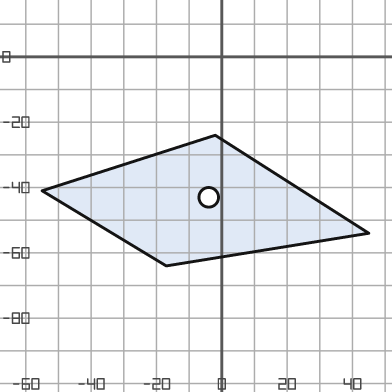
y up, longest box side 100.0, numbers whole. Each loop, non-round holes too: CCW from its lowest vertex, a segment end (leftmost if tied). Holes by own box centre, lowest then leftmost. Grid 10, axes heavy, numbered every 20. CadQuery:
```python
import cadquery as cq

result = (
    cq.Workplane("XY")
    .moveTo(-17.0, -64.0)
    .lineTo(45.0, -54.0)
    .lineTo(-2.0, -24.0)
    .lineTo(-55.0, -41.0)
    .close()
    .moveTo(-4.0, -43.0)
    .circle(3.0)
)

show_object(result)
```